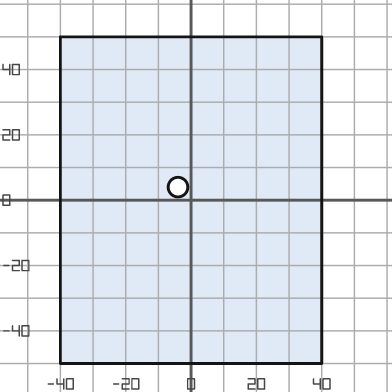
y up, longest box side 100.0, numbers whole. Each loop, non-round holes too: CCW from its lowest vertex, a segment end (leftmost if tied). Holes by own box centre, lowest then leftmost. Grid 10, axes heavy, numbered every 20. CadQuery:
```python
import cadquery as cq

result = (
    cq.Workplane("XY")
    .moveTo(-40.0, -50.0)
    .lineTo(40.0, -50.0)
    .lineTo(40.0, 50.0)
    .lineTo(-40.0, 50.0)
    .close()
    .moveTo(-4.0, 4.0)
    .circle(3.0)
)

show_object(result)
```